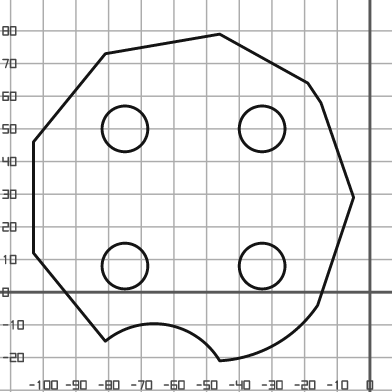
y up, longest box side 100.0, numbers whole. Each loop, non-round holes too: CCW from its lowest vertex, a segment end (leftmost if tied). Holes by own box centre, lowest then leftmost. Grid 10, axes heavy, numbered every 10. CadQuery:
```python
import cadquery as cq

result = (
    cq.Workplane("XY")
    .moveTo(-46.0, -21.0)
    .threePointArc((-29.0, -16.0), (-16.0, -4.0))
    .lineTo(-5.0, 29.0)
    .lineTo(-15.0, 58.0)
    .lineTo(-19.0, 64.0)
    .lineTo(-46.0, 79.0)
    .lineTo(-81.0, 73.0)
    .lineTo(-103.0, 46.0)
    .lineTo(-103.0, 12.0)
    .lineTo(-81.0, -15.0)
    .threePointArc((-62.0, -10.0), (-46.0, -21.0))
    .close()
    .moveTo(-75.0, 8.0)
    .circle(7.0)
    .moveTo(-33.0, 8.0)
    .circle(7.0)
    .moveTo(-75.0, 50.0)
    .circle(7.0)
    .moveTo(-33.0, 50.0)
    .circle(7.0)
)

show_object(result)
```